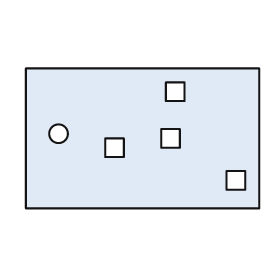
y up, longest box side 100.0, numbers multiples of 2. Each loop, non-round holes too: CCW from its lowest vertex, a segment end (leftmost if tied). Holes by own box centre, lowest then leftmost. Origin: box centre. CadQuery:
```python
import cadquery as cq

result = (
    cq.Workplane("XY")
    .moveTo(-50.0, -30.0)
    .lineTo(50.0, -30.0)
    .lineTo(50.0, 30.0)
    .lineTo(-50.0, 30.0)
    .close()
    .moveTo(36.0, -22.0)
    .lineTo(44.0, -22.0)
    .lineTo(44.0, -14.0)
    .lineTo(36.0, -14.0)
    .close()
    .moveTo(-16.0, -8.0)
    .lineTo(-8.0, -8.0)
    .lineTo(-8.0, 0.0)
    .lineTo(-16.0, 0.0)
    .close()
    .moveTo(8.0, -4.0)
    .lineTo(16.0, -4.0)
    .lineTo(16.0, 4.0)
    .lineTo(8.0, 4.0)
    .close()
    .moveTo(-36.0, 2.0)
    .circle(4.0)
    .moveTo(10.0, 16.0)
    .lineTo(18.0, 16.0)
    .lineTo(18.0, 24.0)
    .lineTo(10.0, 24.0)
    .close()
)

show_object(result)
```